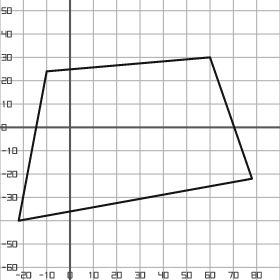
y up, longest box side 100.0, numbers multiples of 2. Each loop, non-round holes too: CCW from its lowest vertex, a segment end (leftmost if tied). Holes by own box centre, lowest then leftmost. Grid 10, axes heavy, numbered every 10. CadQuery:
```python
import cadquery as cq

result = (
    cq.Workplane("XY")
    .moveTo(-22.0, -40.0)
    .lineTo(78.0, -22.0)
    .lineTo(60.0, 30.0)
    .lineTo(-10.0, 24.0)
    .close()
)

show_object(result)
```